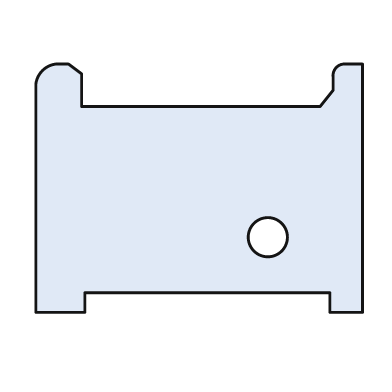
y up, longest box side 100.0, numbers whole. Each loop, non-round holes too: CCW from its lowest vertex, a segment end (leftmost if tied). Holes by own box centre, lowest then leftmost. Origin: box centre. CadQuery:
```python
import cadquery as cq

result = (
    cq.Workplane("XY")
    .moveTo(-50.0, -38.0)
    .lineTo(-35.0, -38.0)
    .lineTo(-35.0, -32.0)
    .lineTo(40.0, -32.0)
    .lineTo(40.0, -38.0)
    .lineTo(50.0, -38.0)
    .lineTo(50.0, 38.0)
    .lineTo(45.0, 38.0)
    .threePointArc((42.0, 37.0), (41.0, 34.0))
    .lineTo(41.0, 30.0)
    .lineTo(37.0, 25.0)
    .lineTo(-36.0, 25.0)
    .lineTo(-36.0, 35.0)
    .lineTo(-40.0, 38.0)
    .lineTo(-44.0, 38.0)
    .threePointArc((-48.0, 36.0), (-50.0, 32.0))
    .close()
    .moveTo(21.0, -15.0)
    .circle(6.0)
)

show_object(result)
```